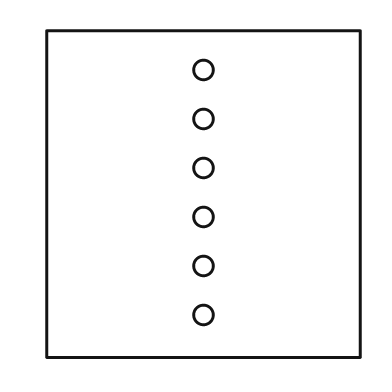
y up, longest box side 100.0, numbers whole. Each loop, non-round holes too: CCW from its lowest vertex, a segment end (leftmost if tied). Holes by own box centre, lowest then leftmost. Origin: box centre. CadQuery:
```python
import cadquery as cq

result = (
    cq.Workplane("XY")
    .moveTo(-48.0, -50.0)
    .lineTo(48.0, -50.0)
    .lineTo(48.0, 50.0)
    .lineTo(-48.0, 50.0)
    .close()
    .moveTo(0.0, -37.0)
    .circle(3.0)
    .moveTo(0.0, -22.0)
    .circle(3.0)
    .moveTo(0.0, -7.0)
    .circle(3.0)
    .moveTo(0.0, 8.0)
    .circle(3.0)
    .moveTo(0.0, 23.0)
    .circle(3.0)
    .moveTo(0.0, 38.0)
    .circle(3.0)
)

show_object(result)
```